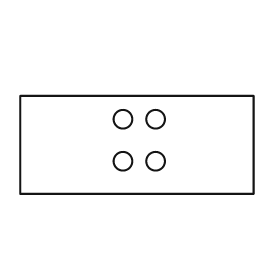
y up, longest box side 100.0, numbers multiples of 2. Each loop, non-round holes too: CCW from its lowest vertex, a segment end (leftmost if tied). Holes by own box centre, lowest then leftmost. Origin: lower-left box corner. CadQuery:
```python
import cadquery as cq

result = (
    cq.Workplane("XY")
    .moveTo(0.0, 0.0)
    .lineTo(100.0, 0.0)
    .lineTo(100.0, 42.0)
    .lineTo(0.0, 42.0)
    .close()
    .moveTo(44.0, 14.0)
    .circle(4.0)
    .moveTo(58.0, 14.0)
    .circle(4.0)
    .moveTo(44.0, 32.0)
    .circle(4.0)
    .moveTo(58.0, 32.0)
    .circle(4.0)
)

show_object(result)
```